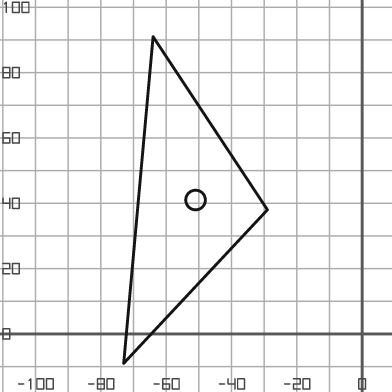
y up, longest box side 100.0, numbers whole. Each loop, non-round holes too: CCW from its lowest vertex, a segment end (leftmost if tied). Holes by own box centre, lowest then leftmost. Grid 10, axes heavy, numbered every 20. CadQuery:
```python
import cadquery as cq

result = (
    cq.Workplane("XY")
    .moveTo(-73.0, -9.0)
    .lineTo(-29.0, 38.0)
    .lineTo(-64.0, 91.0)
    .close()
    .moveTo(-51.0, 41.0)
    .circle(3.0)
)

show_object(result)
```